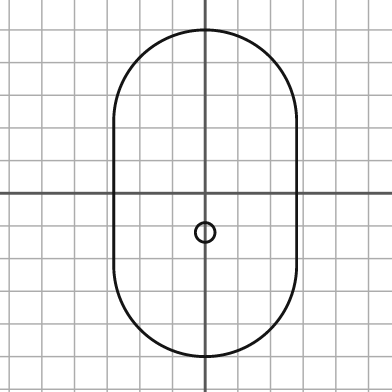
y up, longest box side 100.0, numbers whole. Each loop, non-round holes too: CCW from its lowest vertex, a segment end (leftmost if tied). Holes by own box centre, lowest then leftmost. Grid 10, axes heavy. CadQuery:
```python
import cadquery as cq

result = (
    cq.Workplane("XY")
    .moveTo(-28.0, -22.0)
    .threePointArc((0.0, -50.0), (28.0, -22.0))
    .lineTo(28.0, 22.0)
    .threePointArc((0.0, 50.0), (-28.0, 22.0))
    .close()
    .moveTo(0.0, -12.0)
    .circle(3.0)
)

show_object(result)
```